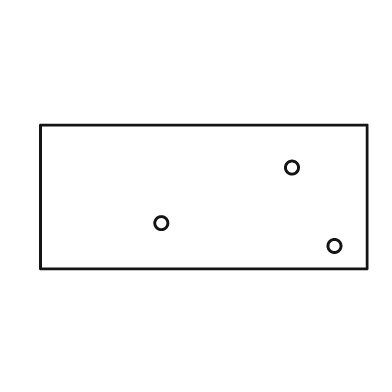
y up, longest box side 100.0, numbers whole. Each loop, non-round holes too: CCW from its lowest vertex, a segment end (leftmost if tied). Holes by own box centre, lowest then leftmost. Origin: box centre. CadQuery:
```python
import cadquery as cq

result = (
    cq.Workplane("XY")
    .moveTo(-50.0, -22.0)
    .lineTo(50.0, -22.0)
    .lineTo(50.0, 22.0)
    .lineTo(-50.0, 22.0)
    .close()
    .moveTo(40.0, -15.0)
    .circle(2.0)
    .moveTo(-13.0, -8.0)
    .circle(2.0)
    .moveTo(27.0, 9.0)
    .circle(2.0)
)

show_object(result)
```